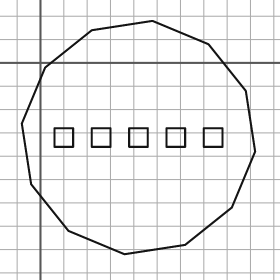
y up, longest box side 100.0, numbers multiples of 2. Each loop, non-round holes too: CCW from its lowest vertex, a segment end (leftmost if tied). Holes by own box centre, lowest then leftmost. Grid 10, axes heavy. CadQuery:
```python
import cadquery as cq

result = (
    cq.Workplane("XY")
    .moveTo(36.0, -82.0)
    .lineTo(62.0, -78.0)
    .lineTo(82.0, -62.0)
    .lineTo(92.0, -38.0)
    .lineTo(88.0, -12.0)
    .lineTo(72.0, 8.0)
    .lineTo(48.0, 18.0)
    .lineTo(22.0, 14.0)
    .lineTo(2.0, -2.0)
    .lineTo(-8.0, -26.0)
    .lineTo(-4.0, -52.0)
    .lineTo(12.0, -72.0)
    .close()
    .moveTo(6.0, -36.0)
    .lineTo(14.0, -36.0)
    .lineTo(14.0, -28.0)
    .lineTo(6.0, -28.0)
    .close()
    .moveTo(22.0, -36.0)
    .lineTo(30.0, -36.0)
    .lineTo(30.0, -28.0)
    .lineTo(22.0, -28.0)
    .close()
    .moveTo(38.0, -36.0)
    .lineTo(46.0, -36.0)
    .lineTo(46.0, -28.0)
    .lineTo(38.0, -28.0)
    .close()
    .moveTo(54.0, -36.0)
    .lineTo(62.0, -36.0)
    .lineTo(62.0, -28.0)
    .lineTo(54.0, -28.0)
    .close()
    .moveTo(70.0, -36.0)
    .lineTo(78.0, -36.0)
    .lineTo(78.0, -28.0)
    .lineTo(70.0, -28.0)
    .close()
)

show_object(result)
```